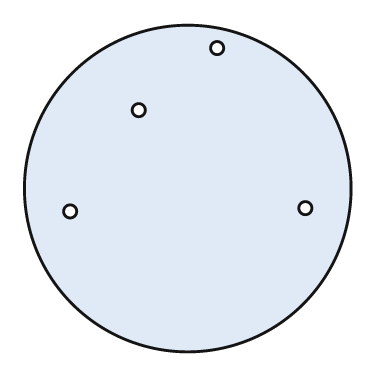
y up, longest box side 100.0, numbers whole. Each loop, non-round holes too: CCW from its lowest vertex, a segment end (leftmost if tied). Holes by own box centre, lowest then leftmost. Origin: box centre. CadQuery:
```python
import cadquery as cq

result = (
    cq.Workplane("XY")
    .moveTo(0.0, 0.0)
    .circle(50.0)
    .moveTo(-36.0, -7.0)
    .circle(2.0)
    .moveTo(36.0, -6.0)
    .circle(2.0)
    .moveTo(-15.0, 24.0)
    .circle(2.0)
    .moveTo(9.0, 43.0)
    .circle(2.0)
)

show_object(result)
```